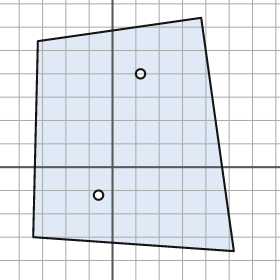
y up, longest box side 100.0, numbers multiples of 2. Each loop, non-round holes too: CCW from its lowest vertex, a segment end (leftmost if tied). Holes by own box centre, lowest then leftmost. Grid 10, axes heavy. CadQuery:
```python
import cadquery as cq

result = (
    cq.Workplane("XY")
    .moveTo(52.0, -36.0)
    .lineTo(38.0, 64.0)
    .lineTo(-32.0, 54.0)
    .lineTo(-34.0, -30.0)
    .close()
    .moveTo(-6.0, -12.0)
    .circle(2.0)
    .moveTo(12.0, 40.0)
    .circle(2.0)
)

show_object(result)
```